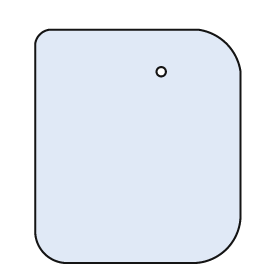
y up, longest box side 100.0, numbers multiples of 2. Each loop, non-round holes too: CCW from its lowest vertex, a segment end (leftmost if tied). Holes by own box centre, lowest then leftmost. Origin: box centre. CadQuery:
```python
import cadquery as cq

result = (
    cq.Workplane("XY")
    .moveTo(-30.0, -50.0)
    .lineTo(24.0, -50.0)
    .threePointArc((38.0, -44.0), (44.0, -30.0))
    .lineTo(44.0, 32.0)
    .threePointArc((38.0, 44.0), (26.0, 50.0))
    .lineTo(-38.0, 50.0)
    .threePointArc((-42.0, 48.0), (-44.0, 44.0))
    .lineTo(-44.0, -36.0)
    .threePointArc((-40.0, -46.0), (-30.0, -50.0))
    .close()
    .moveTo(10.0, 32.0)
    .circle(2.0)
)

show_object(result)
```